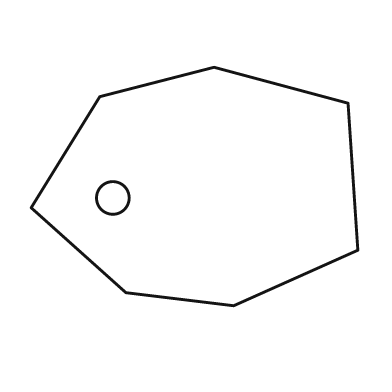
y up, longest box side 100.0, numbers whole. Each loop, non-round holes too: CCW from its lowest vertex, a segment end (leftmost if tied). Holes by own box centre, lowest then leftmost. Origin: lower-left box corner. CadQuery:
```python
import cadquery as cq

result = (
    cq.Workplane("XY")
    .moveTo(62.0, 0.0)
    .lineTo(100.0, 17.0)
    .lineTo(97.0, 62.0)
    .lineTo(56.0, 73.0)
    .lineTo(21.0, 64.0)
    .lineTo(0.0, 30.0)
    .lineTo(29.0, 4.0)
    .close()
    .moveTo(25.0, 33.0)
    .circle(5.0)
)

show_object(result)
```